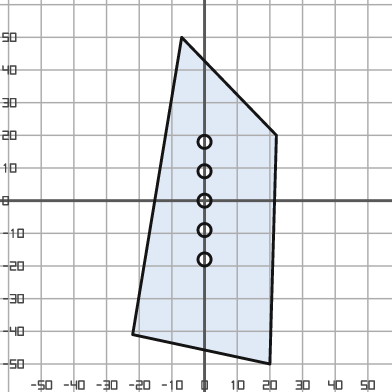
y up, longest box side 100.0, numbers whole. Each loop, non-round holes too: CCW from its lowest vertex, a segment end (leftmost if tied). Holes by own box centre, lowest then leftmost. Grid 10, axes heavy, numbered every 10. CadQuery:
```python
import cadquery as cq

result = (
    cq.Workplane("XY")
    .moveTo(20.0, -50.0)
    .lineTo(22.0, 20.0)
    .lineTo(-7.0, 50.0)
    .lineTo(-22.0, -41.0)
    .close()
    .moveTo(0.0, -18.0)
    .circle(2.0)
    .moveTo(0.0, -9.0)
    .circle(2.0)
    .moveTo(0.0, 0.0)
    .circle(2.0)
    .moveTo(0.0, 9.0)
    .circle(2.0)
    .moveTo(0.0, 18.0)
    .circle(2.0)
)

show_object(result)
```